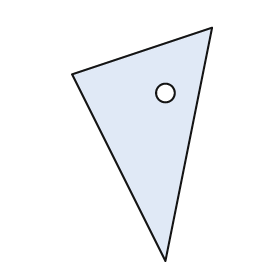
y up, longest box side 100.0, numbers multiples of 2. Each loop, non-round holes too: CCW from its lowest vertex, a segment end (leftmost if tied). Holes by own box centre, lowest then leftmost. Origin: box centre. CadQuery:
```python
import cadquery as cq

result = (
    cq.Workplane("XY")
    .moveTo(10.0, -50.0)
    .lineTo(30.0, 50.0)
    .lineTo(-30.0, 30.0)
    .close()
    .moveTo(10.0, 22.0)
    .circle(4.0)
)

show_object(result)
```